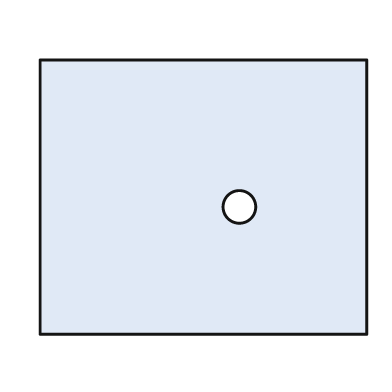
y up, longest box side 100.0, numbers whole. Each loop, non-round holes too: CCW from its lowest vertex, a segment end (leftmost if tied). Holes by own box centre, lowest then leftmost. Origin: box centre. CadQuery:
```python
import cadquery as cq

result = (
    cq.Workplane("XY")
    .moveTo(-50.0, -42.0)
    .lineTo(50.0, -42.0)
    .lineTo(50.0, 42.0)
    .lineTo(-50.0, 42.0)
    .close()
    .moveTo(11.0, -3.0)
    .circle(5.0)
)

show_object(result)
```